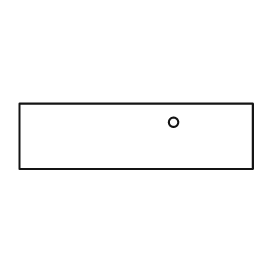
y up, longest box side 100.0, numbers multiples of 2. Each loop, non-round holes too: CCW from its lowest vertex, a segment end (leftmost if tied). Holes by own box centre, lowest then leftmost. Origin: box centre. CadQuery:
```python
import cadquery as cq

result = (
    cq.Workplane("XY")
    .moveTo(-50.0, -14.0)
    .lineTo(50.0, -14.0)
    .lineTo(50.0, 14.0)
    .lineTo(-50.0, 14.0)
    .close()
    .moveTo(16.0, 6.0)
    .circle(2.0)
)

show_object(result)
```